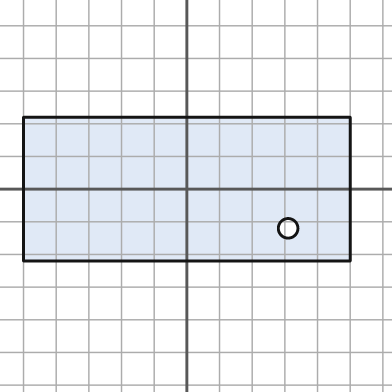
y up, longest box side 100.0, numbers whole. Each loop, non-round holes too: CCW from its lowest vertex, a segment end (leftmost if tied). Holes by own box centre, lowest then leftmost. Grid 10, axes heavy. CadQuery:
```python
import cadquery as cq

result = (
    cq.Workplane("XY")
    .moveTo(-50.0, -22.0)
    .lineTo(50.0, -22.0)
    .lineTo(50.0, 22.0)
    .lineTo(-50.0, 22.0)
    .close()
    .moveTo(31.0, -12.0)
    .circle(3.0)
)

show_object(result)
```